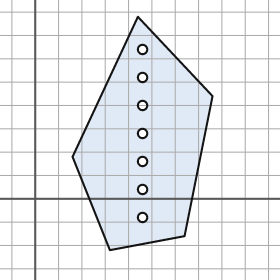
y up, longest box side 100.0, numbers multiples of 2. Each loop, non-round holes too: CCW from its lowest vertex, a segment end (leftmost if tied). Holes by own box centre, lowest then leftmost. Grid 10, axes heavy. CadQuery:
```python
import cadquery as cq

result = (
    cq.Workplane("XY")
    .moveTo(32.0, -22.0)
    .lineTo(64.0, -16.0)
    .lineTo(76.0, 44.0)
    .lineTo(44.0, 78.0)
    .lineTo(16.0, 18.0)
    .close()
    .moveTo(46.0, -8.0)
    .circle(2.0)
    .moveTo(46.0, 4.0)
    .circle(2.0)
    .moveTo(46.0, 16.0)
    .circle(2.0)
    .moveTo(46.0, 28.0)
    .circle(2.0)
    .moveTo(46.0, 40.0)
    .circle(2.0)
    .moveTo(46.0, 52.0)
    .circle(2.0)
    .moveTo(46.0, 64.0)
    .circle(2.0)
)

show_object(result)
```